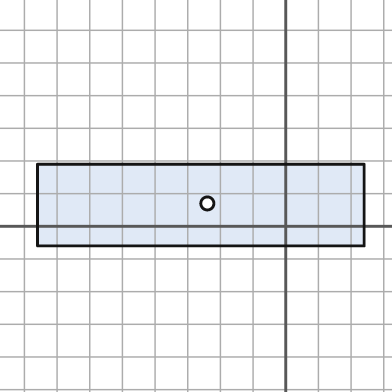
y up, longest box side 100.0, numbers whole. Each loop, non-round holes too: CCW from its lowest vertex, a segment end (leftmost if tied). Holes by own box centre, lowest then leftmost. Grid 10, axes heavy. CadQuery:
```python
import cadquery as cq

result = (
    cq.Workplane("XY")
    .moveTo(-76.0, -6.0)
    .lineTo(24.0, -6.0)
    .lineTo(24.0, 19.0)
    .lineTo(-76.0, 19.0)
    .close()
    .moveTo(-24.0, 7.0)
    .circle(2.0)
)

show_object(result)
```